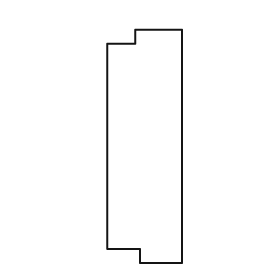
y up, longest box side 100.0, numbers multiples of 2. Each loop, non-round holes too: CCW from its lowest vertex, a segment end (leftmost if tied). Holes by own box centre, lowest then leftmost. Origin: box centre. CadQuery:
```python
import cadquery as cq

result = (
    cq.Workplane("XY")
    .moveTo(-2.0, -50.0)
    .lineTo(16.0, -50.0)
    .lineTo(16.0, 50.0)
    .lineTo(-4.0, 50.0)
    .lineTo(-4.0, 44.0)
    .lineTo(-16.0, 44.0)
    .lineTo(-16.0, -44.0)
    .lineTo(-2.0, -44.0)
    .close()
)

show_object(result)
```